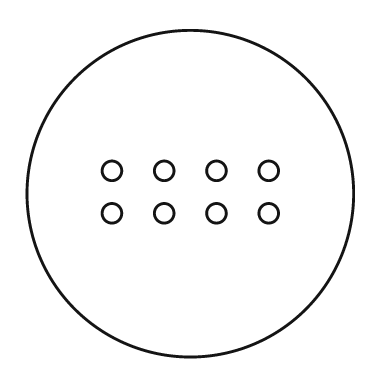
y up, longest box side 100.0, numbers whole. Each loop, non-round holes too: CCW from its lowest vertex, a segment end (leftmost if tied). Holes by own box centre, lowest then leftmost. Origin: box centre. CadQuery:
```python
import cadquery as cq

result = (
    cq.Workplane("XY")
    .moveTo(0.0, 0.0)
    .circle(50.0)
    .moveTo(-24.0, -6.0)
    .circle(3.0)
    .moveTo(-8.0, -6.0)
    .circle(3.0)
    .moveTo(8.0, -6.0)
    .circle(3.0)
    .moveTo(24.0, -6.0)
    .circle(3.0)
    .moveTo(-24.0, 7.0)
    .circle(3.0)
    .moveTo(-8.0, 7.0)
    .circle(3.0)
    .moveTo(8.0, 7.0)
    .circle(3.0)
    .moveTo(24.0, 7.0)
    .circle(3.0)
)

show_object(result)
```